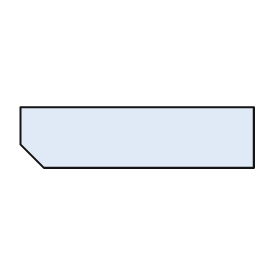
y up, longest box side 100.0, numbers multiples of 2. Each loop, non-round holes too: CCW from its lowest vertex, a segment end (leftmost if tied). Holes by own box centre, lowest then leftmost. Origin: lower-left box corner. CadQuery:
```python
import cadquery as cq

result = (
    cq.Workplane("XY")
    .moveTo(10.0, 0.0)
    .lineTo(100.0, 0.0)
    .lineTo(100.0, 26.0)
    .lineTo(0.0, 26.0)
    .lineTo(0.0, 10.0)
    .close()
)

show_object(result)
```